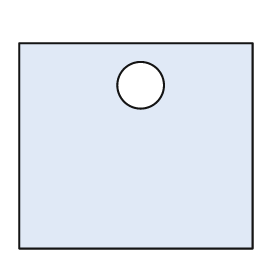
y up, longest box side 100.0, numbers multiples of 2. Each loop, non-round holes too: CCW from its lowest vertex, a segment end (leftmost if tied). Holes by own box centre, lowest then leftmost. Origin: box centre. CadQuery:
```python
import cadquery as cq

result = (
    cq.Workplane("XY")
    .moveTo(-50.0, -44.0)
    .lineTo(50.0, -44.0)
    .lineTo(50.0, 44.0)
    .lineTo(-50.0, 44.0)
    .close()
    .moveTo(2.0, 26.0)
    .circle(10.0)
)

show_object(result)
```